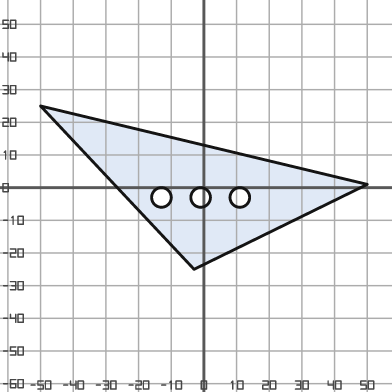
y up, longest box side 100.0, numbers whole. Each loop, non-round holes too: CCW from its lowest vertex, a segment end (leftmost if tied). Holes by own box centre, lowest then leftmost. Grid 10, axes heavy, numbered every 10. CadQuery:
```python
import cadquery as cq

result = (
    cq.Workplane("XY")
    .moveTo(-3.0, -25.0)
    .lineTo(50.0, 1.0)
    .lineTo(-50.0, 25.0)
    .close()
    .moveTo(-13.0, -3.0)
    .circle(3.0)
    .moveTo(-1.0, -3.0)
    .circle(3.0)
    .moveTo(11.0, -3.0)
    .circle(3.0)
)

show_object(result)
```